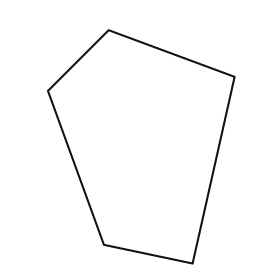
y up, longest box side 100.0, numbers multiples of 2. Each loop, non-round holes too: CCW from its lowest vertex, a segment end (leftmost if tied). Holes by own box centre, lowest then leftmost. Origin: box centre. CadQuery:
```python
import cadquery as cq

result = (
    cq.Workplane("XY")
    .moveTo(22.0, -50.0)
    .lineTo(40.0, 30.0)
    .lineTo(-14.0, 50.0)
    .lineTo(-40.0, 24.0)
    .lineTo(-16.0, -42.0)
    .close()
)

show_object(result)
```